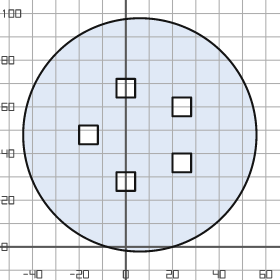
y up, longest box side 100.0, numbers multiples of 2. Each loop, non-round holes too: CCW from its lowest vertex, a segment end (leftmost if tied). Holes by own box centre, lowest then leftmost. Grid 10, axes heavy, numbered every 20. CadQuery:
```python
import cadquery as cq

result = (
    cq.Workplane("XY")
    .moveTo(6.0, 48.0)
    .circle(50.0)
    .moveTo(-4.0, 24.0)
    .lineTo(4.0, 24.0)
    .lineTo(4.0, 32.0)
    .lineTo(-4.0, 32.0)
    .close()
    .moveTo(20.0, 32.0)
    .lineTo(28.0, 32.0)
    .lineTo(28.0, 40.0)
    .lineTo(20.0, 40.0)
    .close()
    .moveTo(-20.0, 44.0)
    .lineTo(-12.0, 44.0)
    .lineTo(-12.0, 52.0)
    .lineTo(-20.0, 52.0)
    .close()
    .moveTo(20.0, 56.0)
    .lineTo(28.0, 56.0)
    .lineTo(28.0, 64.0)
    .lineTo(20.0, 64.0)
    .close()
    .moveTo(-4.0, 64.0)
    .lineTo(4.0, 64.0)
    .lineTo(4.0, 72.0)
    .lineTo(-4.0, 72.0)
    .close()
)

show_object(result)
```